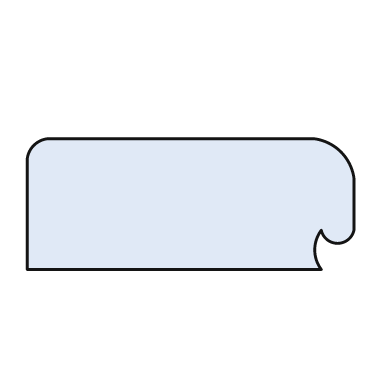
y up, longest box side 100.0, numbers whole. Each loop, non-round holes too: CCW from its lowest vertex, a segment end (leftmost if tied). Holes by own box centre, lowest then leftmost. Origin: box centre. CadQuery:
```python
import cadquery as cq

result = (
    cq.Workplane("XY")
    .moveTo(-50.0, -20.0)
    .lineTo(40.0, -20.0)
    .threePointArc((38.0, -14.0), (40.0, -8.0))
    .threePointArc((45.0, -12.0), (50.0, -8.0))
    .lineTo(50.0, 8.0)
    .threePointArc((46.0, 16.0), (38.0, 20.0))
    .lineTo(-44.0, 20.0)
    .threePointArc((-48.0, 18.0), (-50.0, 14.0))
    .close()
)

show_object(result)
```